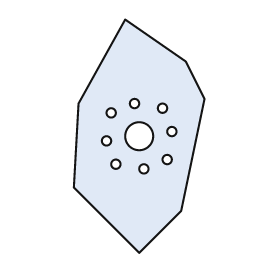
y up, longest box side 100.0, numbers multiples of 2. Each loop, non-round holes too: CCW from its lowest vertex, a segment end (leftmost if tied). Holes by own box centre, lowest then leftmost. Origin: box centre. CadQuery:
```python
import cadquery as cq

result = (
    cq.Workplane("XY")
    .moveTo(0.0, -50.0)
    .lineTo(18.0, -32.0)
    .lineTo(28.0, 16.0)
    .lineTo(20.0, 32.0)
    .lineTo(-6.0, 50.0)
    .lineTo(-26.0, 14.0)
    .lineTo(-28.0, -22.0)
    .close()
    .moveTo(2.0, -14.0)
    .circle(2.0)
    .moveTo(-10.0, -12.0)
    .circle(2.0)
    .moveTo(12.0, -10.0)
    .circle(2.0)
    .moveTo(-14.0, -2.0)
    .circle(2.0)
    .moveTo(0.0, 0.0)
    .circle(6.0)
    .moveTo(14.0, 2.0)
    .circle(2.0)
    .moveTo(-12.0, 10.0)
    .circle(2.0)
    .moveTo(10.0, 12.0)
    .circle(2.0)
    .moveTo(-2.0, 14.0)
    .circle(2.0)
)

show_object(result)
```